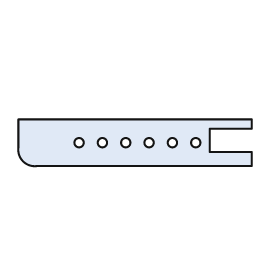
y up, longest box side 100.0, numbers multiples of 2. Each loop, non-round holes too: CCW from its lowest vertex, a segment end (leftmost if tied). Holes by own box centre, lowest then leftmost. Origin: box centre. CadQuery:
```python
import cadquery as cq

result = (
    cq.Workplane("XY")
    .moveTo(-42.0, -10.0)
    .lineTo(50.0, -10.0)
    .lineTo(50.0, -4.0)
    .lineTo(32.0, -4.0)
    .lineTo(32.0, 6.0)
    .lineTo(50.0, 6.0)
    .lineTo(50.0, 10.0)
    .lineTo(-50.0, 10.0)
    .lineTo(-50.0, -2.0)
    .threePointArc((-48.0, -8.0), (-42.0, -10.0))
    .close()
    .moveTo(-24.0, 0.0)
    .circle(2.0)
    .moveTo(-14.0, 0.0)
    .circle(2.0)
    .moveTo(-4.0, 0.0)
    .circle(2.0)
    .moveTo(6.0, 0.0)
    .circle(2.0)
    .moveTo(16.0, 0.0)
    .circle(2.0)
    .moveTo(26.0, 0.0)
    .circle(2.0)
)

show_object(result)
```